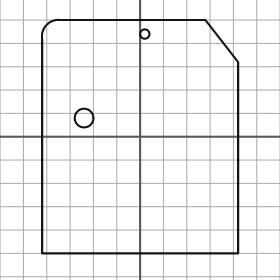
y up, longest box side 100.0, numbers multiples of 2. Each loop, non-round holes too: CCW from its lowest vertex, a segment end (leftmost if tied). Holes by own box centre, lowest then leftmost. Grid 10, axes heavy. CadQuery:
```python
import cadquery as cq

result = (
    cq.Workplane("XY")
    .moveTo(-42.0, -50.0)
    .lineTo(42.0, -50.0)
    .lineTo(42.0, 32.0)
    .lineTo(28.0, 50.0)
    .lineTo(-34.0, 50.0)
    .threePointArc((-40.0, 48.0), (-42.0, 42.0))
    .close()
    .moveTo(-24.0, 8.0)
    .circle(4.0)
    .moveTo(2.0, 44.0)
    .circle(2.0)
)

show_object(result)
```